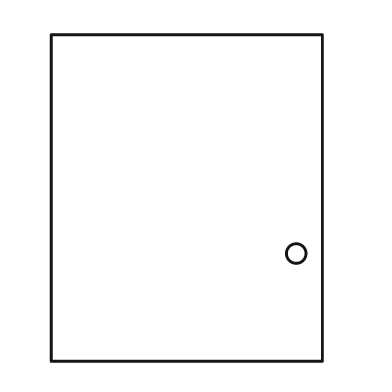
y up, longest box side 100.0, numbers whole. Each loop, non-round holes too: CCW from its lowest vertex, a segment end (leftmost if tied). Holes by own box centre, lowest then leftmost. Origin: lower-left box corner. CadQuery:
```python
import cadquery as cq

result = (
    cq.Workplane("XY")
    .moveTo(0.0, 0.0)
    .lineTo(83.0, 0.0)
    .lineTo(83.0, 100.0)
    .lineTo(0.0, 100.0)
    .close()
    .moveTo(75.0, 33.0)
    .circle(3.0)
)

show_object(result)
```